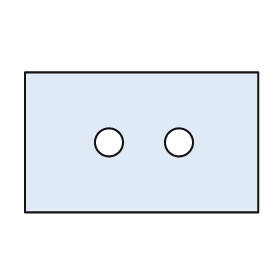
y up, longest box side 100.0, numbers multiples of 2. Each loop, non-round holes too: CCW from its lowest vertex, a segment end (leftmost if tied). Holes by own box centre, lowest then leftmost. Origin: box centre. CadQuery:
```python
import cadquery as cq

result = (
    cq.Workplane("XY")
    .moveTo(-50.0, -30.0)
    .lineTo(50.0, -30.0)
    .lineTo(50.0, 30.0)
    .lineTo(-50.0, 30.0)
    .close()
    .moveTo(-14.0, 0.0)
    .circle(6.0)
    .moveTo(16.0, 0.0)
    .circle(6.0)
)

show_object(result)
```